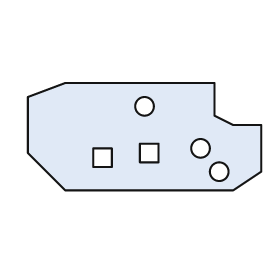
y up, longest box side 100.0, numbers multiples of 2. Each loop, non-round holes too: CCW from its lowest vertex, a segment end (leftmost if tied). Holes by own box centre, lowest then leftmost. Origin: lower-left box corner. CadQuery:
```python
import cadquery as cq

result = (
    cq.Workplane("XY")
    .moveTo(16.0, 0.0)
    .lineTo(88.0, 0.0)
    .lineTo(100.0, 8.0)
    .lineTo(100.0, 28.0)
    .lineTo(88.0, 28.0)
    .lineTo(80.0, 32.0)
    .lineTo(80.0, 46.0)
    .lineTo(16.0, 46.0)
    .lineTo(0.0, 40.0)
    .lineTo(0.0, 16.0)
    .close()
    .moveTo(82.0, 8.0)
    .circle(4.0)
    .moveTo(28.0, 10.0)
    .lineTo(36.0, 10.0)
    .lineTo(36.0, 18.0)
    .lineTo(28.0, 18.0)
    .close()
    .moveTo(48.0, 12.0)
    .lineTo(56.0, 12.0)
    .lineTo(56.0, 20.0)
    .lineTo(48.0, 20.0)
    .close()
    .moveTo(74.0, 18.0)
    .circle(4.0)
    .moveTo(50.0, 36.0)
    .circle(4.0)
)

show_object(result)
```